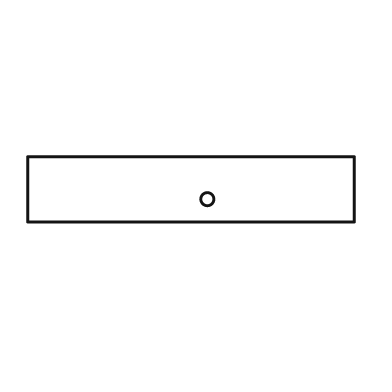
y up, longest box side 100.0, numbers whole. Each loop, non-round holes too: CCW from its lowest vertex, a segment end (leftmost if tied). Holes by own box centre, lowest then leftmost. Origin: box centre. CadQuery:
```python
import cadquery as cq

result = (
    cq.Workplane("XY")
    .moveTo(-50.0, -10.0)
    .lineTo(50.0, -10.0)
    .lineTo(50.0, 10.0)
    .lineTo(-50.0, 10.0)
    .close()
    .moveTo(5.0, -3.0)
    .circle(2.0)
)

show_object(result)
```